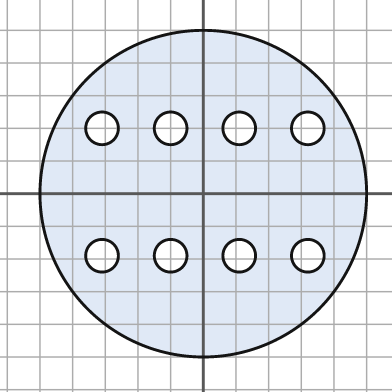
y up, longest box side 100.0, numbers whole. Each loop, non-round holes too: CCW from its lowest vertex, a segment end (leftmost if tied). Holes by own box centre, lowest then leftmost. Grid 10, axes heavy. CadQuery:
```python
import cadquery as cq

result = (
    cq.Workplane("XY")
    .moveTo(0.0, 0.0)
    .circle(50.0)
    .moveTo(-31.0, -19.0)
    .circle(5.0)
    .moveTo(-10.0, -19.0)
    .circle(5.0)
    .moveTo(11.0, -19.0)
    .circle(5.0)
    .moveTo(32.0, -19.0)
    .circle(5.0)
    .moveTo(-31.0, 20.0)
    .circle(5.0)
    .moveTo(-10.0, 20.0)
    .circle(5.0)
    .moveTo(11.0, 20.0)
    .circle(5.0)
    .moveTo(32.0, 20.0)
    .circle(5.0)
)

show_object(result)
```